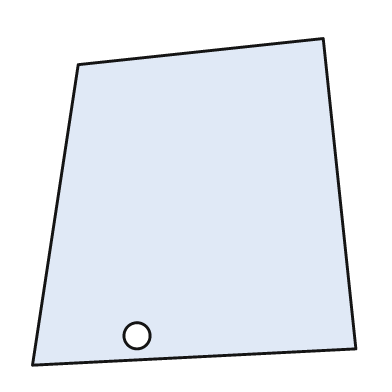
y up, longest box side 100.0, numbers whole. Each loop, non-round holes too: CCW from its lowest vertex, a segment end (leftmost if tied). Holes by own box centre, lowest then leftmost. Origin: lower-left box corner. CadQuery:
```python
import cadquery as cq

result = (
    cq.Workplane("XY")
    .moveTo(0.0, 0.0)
    .lineTo(99.0, 5.0)
    .lineTo(89.0, 100.0)
    .lineTo(14.0, 92.0)
    .close()
    .moveTo(32.0, 9.0)
    .circle(4.0)
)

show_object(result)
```